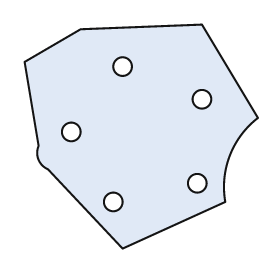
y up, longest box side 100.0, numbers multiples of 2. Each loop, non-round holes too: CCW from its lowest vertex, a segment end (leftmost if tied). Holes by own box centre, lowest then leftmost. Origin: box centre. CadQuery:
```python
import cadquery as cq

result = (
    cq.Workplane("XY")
    .moveTo(-8.0, -48.0)
    .lineTo(36.0, -28.0)
    .threePointArc((38.0, -8.0), (50.0, 8.0))
    .lineTo(26.0, 48.0)
    .lineTo(-26.0, 46.0)
    .lineTo(-50.0, 32.0)
    .lineTo(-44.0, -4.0)
    .threePointArc((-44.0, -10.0), (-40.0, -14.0))
    .close()
    .moveTo(-12.0, -28.0)
    .circle(4.0)
    .moveTo(24.0, -20.0)
    .circle(4.0)
    .moveTo(-30.0, 2.0)
    .circle(4.0)
    .moveTo(26.0, 16.0)
    .circle(4.0)
    .moveTo(-8.0, 30.0)
    .circle(4.0)
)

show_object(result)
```